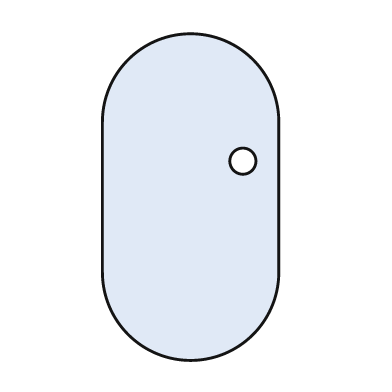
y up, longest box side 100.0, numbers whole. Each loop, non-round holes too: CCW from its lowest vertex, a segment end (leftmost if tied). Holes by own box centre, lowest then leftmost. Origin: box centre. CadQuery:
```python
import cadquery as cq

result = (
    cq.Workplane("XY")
    .moveTo(-27.0, -23.0)
    .threePointArc((0.0, -50.0), (27.0, -23.0))
    .lineTo(27.0, 23.0)
    .threePointArc((0.0, 50.0), (-27.0, 23.0))
    .close()
    .moveTo(16.0, 11.0)
    .circle(4.0)
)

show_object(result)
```